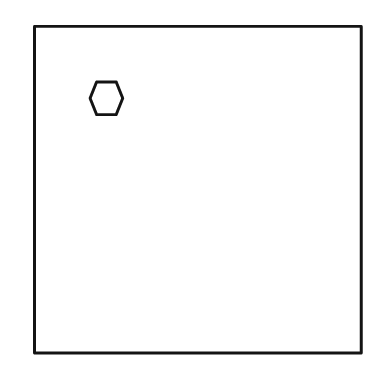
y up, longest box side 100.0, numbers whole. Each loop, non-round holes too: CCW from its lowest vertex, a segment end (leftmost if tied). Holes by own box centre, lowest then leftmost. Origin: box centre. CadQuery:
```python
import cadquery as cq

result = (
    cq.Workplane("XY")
    .moveTo(-50.0, -50.0)
    .lineTo(50.0, -50.0)
    .lineTo(50.0, 50.0)
    .lineTo(-50.0, 50.0)
    .close()
    .moveTo(-31.0, 23.0)
    .lineTo(-25.0, 23.0)
    .lineTo(-23.0, 28.0)
    .lineTo(-25.0, 33.0)
    .lineTo(-31.0, 33.0)
    .lineTo(-33.0, 28.0)
    .close()
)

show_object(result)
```